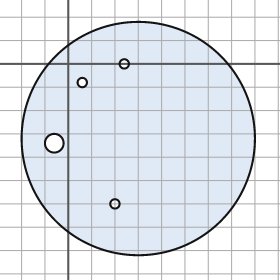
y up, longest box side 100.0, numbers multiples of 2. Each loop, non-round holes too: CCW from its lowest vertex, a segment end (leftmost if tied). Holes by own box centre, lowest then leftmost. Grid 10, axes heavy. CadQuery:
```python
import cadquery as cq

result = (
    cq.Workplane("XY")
    .moveTo(30.0, -32.0)
    .circle(50.0)
    .moveTo(20.0, -60.0)
    .circle(2.0)
    .moveTo(-6.0, -34.0)
    .circle(4.0)
    .moveTo(6.0, -8.0)
    .circle(2.0)
    .moveTo(24.0, 0.0)
    .circle(2.0)
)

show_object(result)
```